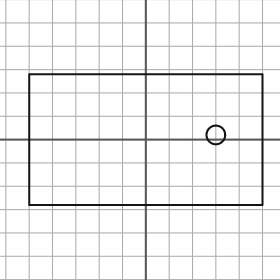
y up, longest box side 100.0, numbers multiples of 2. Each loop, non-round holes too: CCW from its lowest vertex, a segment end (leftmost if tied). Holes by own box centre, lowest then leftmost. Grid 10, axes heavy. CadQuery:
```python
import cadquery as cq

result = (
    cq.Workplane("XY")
    .moveTo(-50.0, -28.0)
    .lineTo(50.0, -28.0)
    .lineTo(50.0, 28.0)
    .lineTo(-50.0, 28.0)
    .close()
    .moveTo(30.0, 2.0)
    .circle(4.0)
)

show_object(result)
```